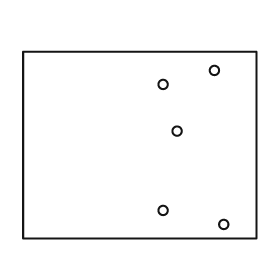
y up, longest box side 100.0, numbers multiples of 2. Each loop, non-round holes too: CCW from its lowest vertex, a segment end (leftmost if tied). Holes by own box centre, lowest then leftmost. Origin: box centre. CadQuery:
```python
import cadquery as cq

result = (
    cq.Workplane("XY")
    .moveTo(-50.0, -40.0)
    .lineTo(50.0, -40.0)
    .lineTo(50.0, 40.0)
    .lineTo(-50.0, 40.0)
    .close()
    .moveTo(36.0, -34.0)
    .circle(2.0)
    .moveTo(10.0, -28.0)
    .circle(2.0)
    .moveTo(16.0, 6.0)
    .circle(2.0)
    .moveTo(10.0, 26.0)
    .circle(2.0)
    .moveTo(32.0, 32.0)
    .circle(2.0)
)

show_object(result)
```